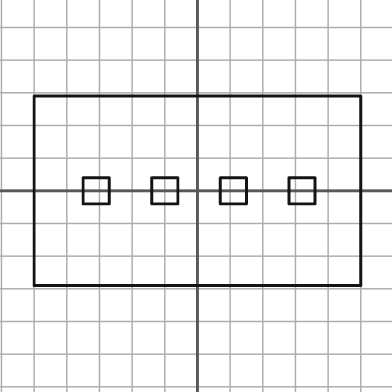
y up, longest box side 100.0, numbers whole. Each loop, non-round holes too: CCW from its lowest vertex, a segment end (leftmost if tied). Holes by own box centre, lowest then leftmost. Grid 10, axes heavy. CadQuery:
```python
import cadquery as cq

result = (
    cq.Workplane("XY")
    .moveTo(-50.0, -29.0)
    .lineTo(50.0, -29.0)
    .lineTo(50.0, 29.0)
    .lineTo(-50.0, 29.0)
    .close()
    .moveTo(-35.0, -4.0)
    .lineTo(-27.0, -4.0)
    .lineTo(-27.0, 4.0)
    .lineTo(-35.0, 4.0)
    .close()
    .moveTo(-14.0, -4.0)
    .lineTo(-6.0, -4.0)
    .lineTo(-6.0, 4.0)
    .lineTo(-14.0, 4.0)
    .close()
    .moveTo(7.0, -4.0)
    .lineTo(15.0, -4.0)
    .lineTo(15.0, 4.0)
    .lineTo(7.0, 4.0)
    .close()
    .moveTo(28.0, -4.0)
    .lineTo(36.0, -4.0)
    .lineTo(36.0, 4.0)
    .lineTo(28.0, 4.0)
    .close()
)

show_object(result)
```